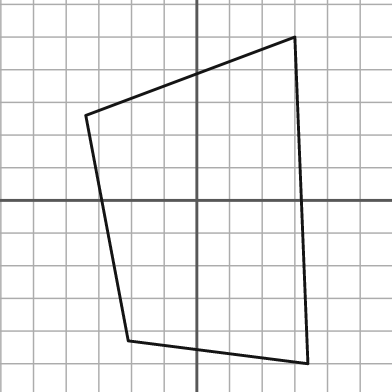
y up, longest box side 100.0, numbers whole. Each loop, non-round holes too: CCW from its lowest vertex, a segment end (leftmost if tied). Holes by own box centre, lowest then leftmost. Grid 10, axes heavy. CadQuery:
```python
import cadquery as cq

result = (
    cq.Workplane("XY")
    .moveTo(34.0, -50.0)
    .lineTo(30.0, 50.0)
    .lineTo(-34.0, 26.0)
    .lineTo(-21.0, -43.0)
    .close()
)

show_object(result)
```